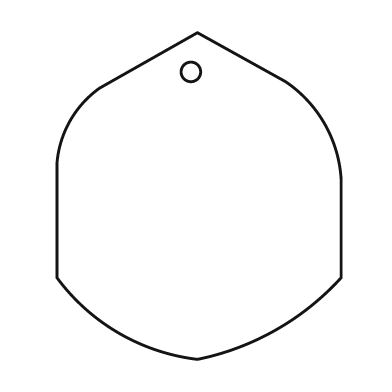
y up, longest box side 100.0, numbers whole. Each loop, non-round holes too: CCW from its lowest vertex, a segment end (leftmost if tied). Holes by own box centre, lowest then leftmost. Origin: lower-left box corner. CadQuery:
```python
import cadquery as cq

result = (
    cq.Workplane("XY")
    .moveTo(43.0, 0.0)
    .threePointArc((67.0, 9.0), (87.0, 25.0))
    .lineTo(87.0, 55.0)
    .threePointArc((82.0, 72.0), (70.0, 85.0))
    .lineTo(43.0, 100.0)
    .lineTo(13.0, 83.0)
    .threePointArc((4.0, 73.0), (0.0, 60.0))
    .lineTo(0.0, 25.0)
    .threePointArc((19.0, 8.0), (43.0, 0.0))
    .close()
    .moveTo(41.0, 88.0)
    .circle(3.0)
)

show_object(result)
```